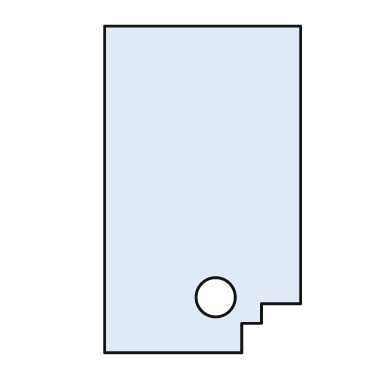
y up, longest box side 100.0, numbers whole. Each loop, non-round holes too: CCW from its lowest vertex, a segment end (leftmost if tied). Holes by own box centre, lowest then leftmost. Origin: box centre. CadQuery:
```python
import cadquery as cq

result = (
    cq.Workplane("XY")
    .moveTo(-30.0, -50.0)
    .lineTo(12.0, -50.0)
    .lineTo(12.0, -41.0)
    .lineTo(18.0, -41.0)
    .lineTo(18.0, -35.0)
    .lineTo(30.0, -35.0)
    .lineTo(30.0, 50.0)
    .lineTo(-30.0, 50.0)
    .close()
    .moveTo(4.0, -33.0)
    .circle(6.0)
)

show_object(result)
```